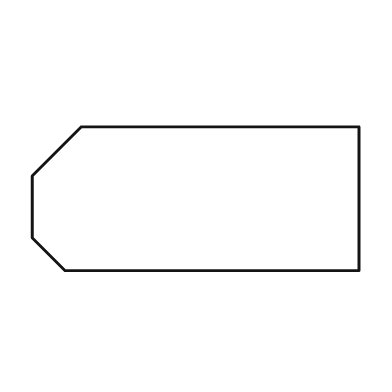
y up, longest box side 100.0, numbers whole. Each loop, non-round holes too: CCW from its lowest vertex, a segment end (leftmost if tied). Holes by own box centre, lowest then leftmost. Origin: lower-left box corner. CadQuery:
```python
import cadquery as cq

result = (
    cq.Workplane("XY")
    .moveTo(10.0, 0.0)
    .lineTo(100.0, 0.0)
    .lineTo(100.0, 44.0)
    .lineTo(15.0, 44.0)
    .lineTo(0.0, 29.0)
    .lineTo(0.0, 10.0)
    .close()
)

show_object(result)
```